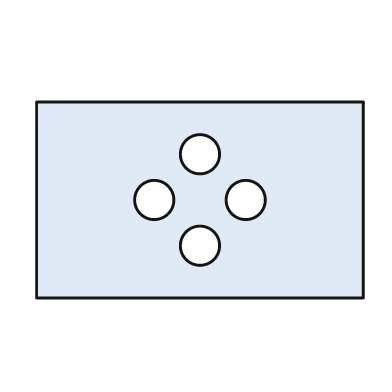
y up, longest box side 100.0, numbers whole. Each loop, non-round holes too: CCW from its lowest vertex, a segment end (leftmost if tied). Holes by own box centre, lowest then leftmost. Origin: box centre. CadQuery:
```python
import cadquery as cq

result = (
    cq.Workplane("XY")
    .moveTo(-50.0, -30.0)
    .lineTo(50.0, -30.0)
    .lineTo(50.0, 30.0)
    .lineTo(-50.0, 30.0)
    .close()
    .moveTo(0.0, -14.0)
    .circle(6.0)
    .moveTo(-14.0, 0.0)
    .circle(6.0)
    .moveTo(14.0, 0.0)
    .circle(6.0)
    .moveTo(0.0, 14.0)
    .circle(6.0)
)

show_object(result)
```